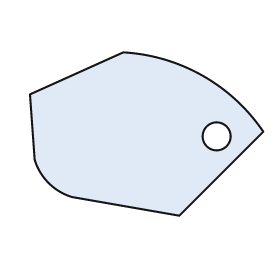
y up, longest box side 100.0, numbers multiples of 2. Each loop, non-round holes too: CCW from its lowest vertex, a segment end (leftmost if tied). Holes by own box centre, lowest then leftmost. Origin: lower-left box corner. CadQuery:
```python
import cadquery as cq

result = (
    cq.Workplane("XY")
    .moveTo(64.0, 0.0)
    .lineTo(100.0, 36.0)
    .threePointArc((74.0, 60.0), (40.0, 70.0))
    .lineTo(0.0, 52.0)
    .lineTo(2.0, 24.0)
    .threePointArc((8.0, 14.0), (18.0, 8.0))
    .close()
    .moveTo(80.0, 34.0)
    .circle(6.0)
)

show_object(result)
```